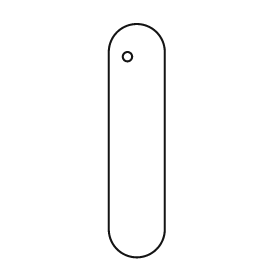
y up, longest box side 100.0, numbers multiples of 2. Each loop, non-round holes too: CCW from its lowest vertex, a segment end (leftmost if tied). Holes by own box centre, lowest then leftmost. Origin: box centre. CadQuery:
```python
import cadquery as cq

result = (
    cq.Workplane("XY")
    .moveTo(-12.0, -38.0)
    .threePointArc((0.0, -50.0), (12.0, -38.0))
    .lineTo(12.0, 38.0)
    .threePointArc((0.0, 50.0), (-12.0, 38.0))
    .close()
    .moveTo(-4.0, 36.0)
    .circle(2.0)
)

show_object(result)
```